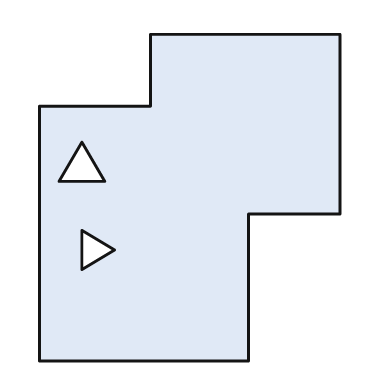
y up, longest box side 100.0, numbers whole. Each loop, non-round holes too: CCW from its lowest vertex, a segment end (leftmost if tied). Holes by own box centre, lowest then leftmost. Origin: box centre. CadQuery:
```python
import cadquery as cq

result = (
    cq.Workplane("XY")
    .moveTo(-46.0, -50.0)
    .lineTo(18.0, -50.0)
    .lineTo(18.0, -5.0)
    .lineTo(46.0, -5.0)
    .lineTo(46.0, 50.0)
    .lineTo(-12.0, 50.0)
    .lineTo(-12.0, 28.0)
    .lineTo(-46.0, 28.0)
    .close()
    .moveTo(-33.0, -22.0)
    .lineTo(-23.0, -16.0)
    .lineTo(-33.0, -10.0)
    .close()
    .moveTo(-40.0, 5.0)
    .lineTo(-26.0, 5.0)
    .lineTo(-33.0, 17.0)
    .close()
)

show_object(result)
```